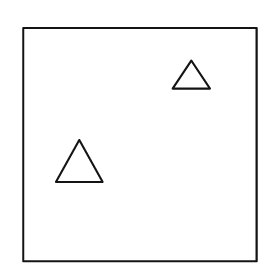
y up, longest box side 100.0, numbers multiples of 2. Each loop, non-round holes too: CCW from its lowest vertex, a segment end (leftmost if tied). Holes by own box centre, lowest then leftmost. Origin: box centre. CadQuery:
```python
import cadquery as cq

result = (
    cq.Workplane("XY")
    .moveTo(-50.0, -50.0)
    .lineTo(50.0, -50.0)
    .lineTo(50.0, 50.0)
    .lineTo(-50.0, 50.0)
    .close()
    .moveTo(-36.0, -16.0)
    .lineTo(-16.0, -16.0)
    .lineTo(-26.0, 2.0)
    .close()
    .moveTo(14.0, 24.0)
    .lineTo(30.0, 24.0)
    .lineTo(22.0, 36.0)
    .close()
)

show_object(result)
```